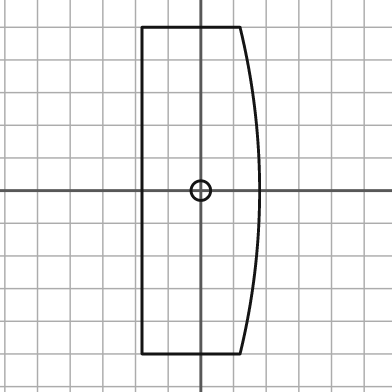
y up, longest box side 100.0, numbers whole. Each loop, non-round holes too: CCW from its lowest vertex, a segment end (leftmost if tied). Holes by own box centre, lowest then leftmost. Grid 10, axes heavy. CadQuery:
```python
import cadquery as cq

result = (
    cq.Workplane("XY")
    .moveTo(-18.0, -50.0)
    .lineTo(12.0, -50.0)
    .threePointArc((18.0, 0.0), (12.0, 50.0))
    .lineTo(-18.0, 50.0)
    .close()
    .moveTo(0.0, 0.0)
    .circle(3.0)
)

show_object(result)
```